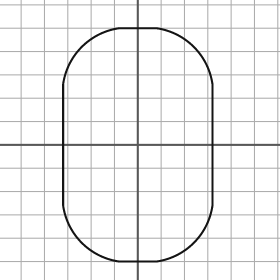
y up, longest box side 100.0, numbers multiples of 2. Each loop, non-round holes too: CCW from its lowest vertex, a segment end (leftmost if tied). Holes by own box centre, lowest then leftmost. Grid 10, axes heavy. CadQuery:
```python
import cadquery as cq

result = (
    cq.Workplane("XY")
    .moveTo(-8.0, -50.0)
    .lineTo(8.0, -50.0)
    .threePointArc((24.0, -42.0), (32.0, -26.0))
    .lineTo(32.0, 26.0)
    .threePointArc((24.0, 42.0), (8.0, 50.0))
    .lineTo(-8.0, 50.0)
    .threePointArc((-24.0, 42.0), (-32.0, 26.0))
    .lineTo(-32.0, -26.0)
    .threePointArc((-24.0, -42.0), (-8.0, -50.0))
    .close()
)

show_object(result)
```